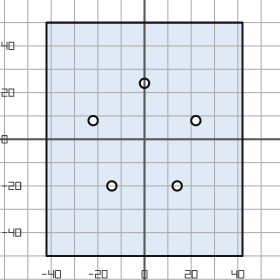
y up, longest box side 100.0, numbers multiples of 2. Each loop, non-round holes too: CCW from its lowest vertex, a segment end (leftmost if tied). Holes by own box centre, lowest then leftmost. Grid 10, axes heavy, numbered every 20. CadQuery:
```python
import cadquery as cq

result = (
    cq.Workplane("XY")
    .moveTo(-42.0, -50.0)
    .lineTo(42.0, -50.0)
    .lineTo(42.0, 50.0)
    .lineTo(-42.0, 50.0)
    .close()
    .moveTo(-14.0, -20.0)
    .circle(2.0)
    .moveTo(14.0, -20.0)
    .circle(2.0)
    .moveTo(-22.0, 8.0)
    .circle(2.0)
    .moveTo(22.0, 8.0)
    .circle(2.0)
    .moveTo(0.0, 24.0)
    .circle(2.0)
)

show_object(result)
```